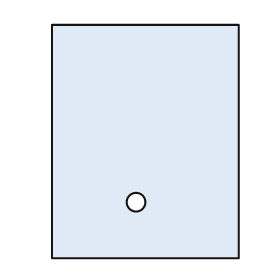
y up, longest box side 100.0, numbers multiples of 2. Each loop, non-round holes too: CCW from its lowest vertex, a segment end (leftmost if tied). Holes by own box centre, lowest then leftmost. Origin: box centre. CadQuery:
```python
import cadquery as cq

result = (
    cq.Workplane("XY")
    .moveTo(-40.0, -50.0)
    .lineTo(40.0, -50.0)
    .lineTo(40.0, 50.0)
    .lineTo(-40.0, 50.0)
    .close()
    .moveTo(-4.0, -26.0)
    .circle(4.0)
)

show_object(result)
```